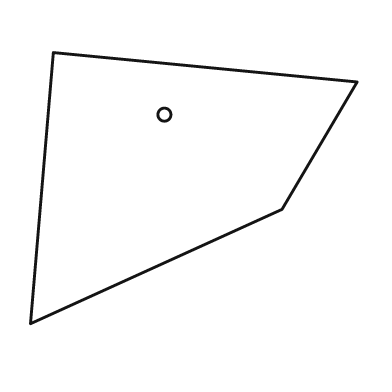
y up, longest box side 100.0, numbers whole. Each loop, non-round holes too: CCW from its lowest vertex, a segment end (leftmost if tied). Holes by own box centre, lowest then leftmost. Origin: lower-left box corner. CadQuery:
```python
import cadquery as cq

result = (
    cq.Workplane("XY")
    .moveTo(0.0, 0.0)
    .lineTo(77.0, 35.0)
    .lineTo(100.0, 74.0)
    .lineTo(7.0, 83.0)
    .close()
    .moveTo(41.0, 64.0)
    .circle(2.0)
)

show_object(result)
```